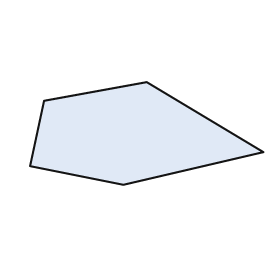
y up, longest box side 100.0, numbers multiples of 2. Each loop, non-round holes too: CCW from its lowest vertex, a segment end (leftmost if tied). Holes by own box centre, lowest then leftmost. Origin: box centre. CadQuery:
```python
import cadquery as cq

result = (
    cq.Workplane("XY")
    .moveTo(-10.0, -22.0)
    .lineTo(50.0, -8.0)
    .lineTo(0.0, 22.0)
    .lineTo(-44.0, 14.0)
    .lineTo(-50.0, -14.0)
    .close()
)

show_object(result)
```